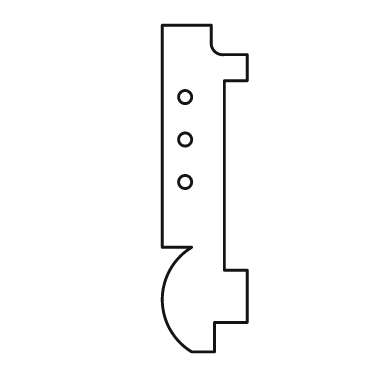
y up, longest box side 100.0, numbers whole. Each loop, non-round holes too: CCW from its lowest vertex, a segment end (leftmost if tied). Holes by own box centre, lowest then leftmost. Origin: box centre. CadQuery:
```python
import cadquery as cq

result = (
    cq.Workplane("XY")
    .moveTo(-4.0, -50.0)
    .lineTo(3.0, -50.0)
    .lineTo(3.0, -41.0)
    .lineTo(13.0, -41.0)
    .lineTo(13.0, -25.0)
    .lineTo(6.0, -25.0)
    .lineTo(6.0, 33.0)
    .lineTo(13.0, 33.0)
    .lineTo(13.0, 41.0)
    .lineTo(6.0, 41.0)
    .threePointArc((3.0, 42.0), (2.0, 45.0))
    .lineTo(2.0, 50.0)
    .lineTo(-13.0, 50.0)
    .lineTo(-13.0, -18.0)
    .lineTo(-4.0, -18.0)
    .threePointArc((-13.0, -34.0), (-4.0, -50.0))
    .close()
    .moveTo(-6.0, 2.0)
    .circle(2.0)
    .moveTo(-6.0, 15.0)
    .circle(2.0)
    .moveTo(-6.0, 28.0)
    .circle(2.0)
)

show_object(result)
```